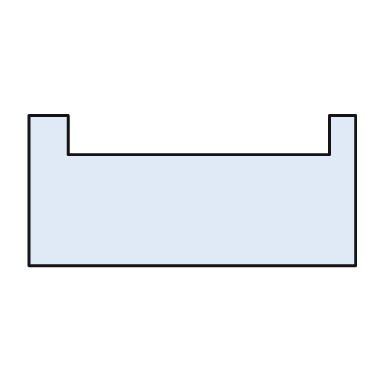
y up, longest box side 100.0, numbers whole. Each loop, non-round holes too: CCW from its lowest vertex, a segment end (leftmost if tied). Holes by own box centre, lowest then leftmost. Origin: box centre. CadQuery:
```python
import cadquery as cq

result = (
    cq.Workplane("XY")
    .moveTo(-50.0, -23.0)
    .lineTo(50.0, -23.0)
    .lineTo(50.0, 23.0)
    .lineTo(42.0, 23.0)
    .lineTo(42.0, 11.0)
    .lineTo(-38.0, 11.0)
    .lineTo(-38.0, 23.0)
    .lineTo(-50.0, 23.0)
    .close()
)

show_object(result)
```